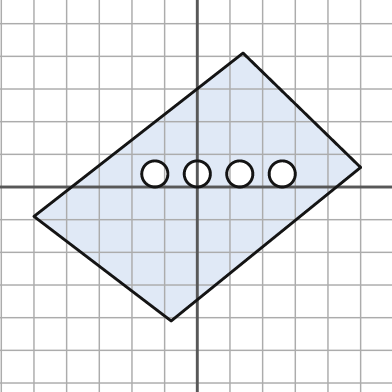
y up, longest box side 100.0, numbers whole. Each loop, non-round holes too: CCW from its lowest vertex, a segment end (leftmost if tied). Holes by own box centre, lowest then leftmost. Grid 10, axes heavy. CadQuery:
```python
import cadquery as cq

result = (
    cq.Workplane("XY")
    .moveTo(-8.0, -41.0)
    .lineTo(50.0, 6.0)
    .lineTo(14.0, 41.0)
    .lineTo(-50.0, -9.0)
    .close()
    .moveTo(-13.0, 4.0)
    .circle(4.0)
    .moveTo(0.0, 4.0)
    .circle(4.0)
    .moveTo(13.0, 4.0)
    .circle(4.0)
    .moveTo(26.0, 4.0)
    .circle(4.0)
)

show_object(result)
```